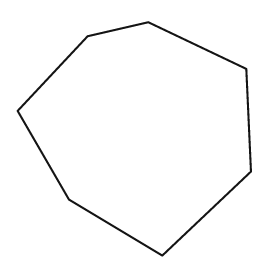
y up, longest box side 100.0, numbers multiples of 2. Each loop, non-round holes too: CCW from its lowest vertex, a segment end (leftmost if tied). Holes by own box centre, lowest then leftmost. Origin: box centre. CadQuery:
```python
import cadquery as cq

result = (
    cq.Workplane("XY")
    .moveTo(12.0, -50.0)
    .lineTo(50.0, -14.0)
    .lineTo(48.0, 30.0)
    .lineTo(6.0, 50.0)
    .lineTo(-20.0, 44.0)
    .lineTo(-50.0, 12.0)
    .lineTo(-28.0, -26.0)
    .close()
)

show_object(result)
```